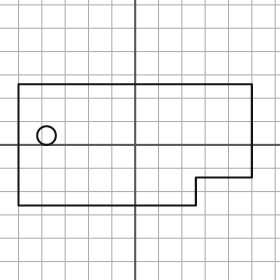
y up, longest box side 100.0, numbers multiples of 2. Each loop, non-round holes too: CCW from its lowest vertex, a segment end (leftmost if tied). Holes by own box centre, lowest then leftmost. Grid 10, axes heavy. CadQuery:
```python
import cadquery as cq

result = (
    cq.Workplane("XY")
    .moveTo(-50.0, -26.0)
    .lineTo(26.0, -26.0)
    .lineTo(26.0, -14.0)
    .lineTo(50.0, -14.0)
    .lineTo(50.0, 26.0)
    .lineTo(-50.0, 26.0)
    .close()
    .moveTo(-38.0, 4.0)
    .circle(4.0)
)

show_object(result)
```